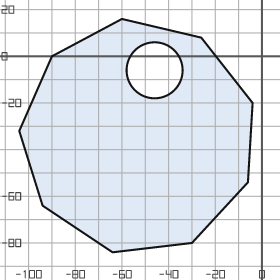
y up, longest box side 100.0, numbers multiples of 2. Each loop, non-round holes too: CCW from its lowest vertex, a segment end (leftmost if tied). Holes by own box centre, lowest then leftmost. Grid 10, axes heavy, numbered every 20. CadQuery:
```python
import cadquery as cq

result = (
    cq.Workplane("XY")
    .moveTo(-64.0, -84.0)
    .lineTo(-30.0, -80.0)
    .lineTo(-6.0, -54.0)
    .lineTo(-4.0, -20.0)
    .lineTo(-26.0, 8.0)
    .lineTo(-60.0, 16.0)
    .lineTo(-90.0, 0.0)
    .lineTo(-104.0, -32.0)
    .lineTo(-94.0, -64.0)
    .close()
    .moveTo(-46.0, -6.0)
    .circle(12.0)
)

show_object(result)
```